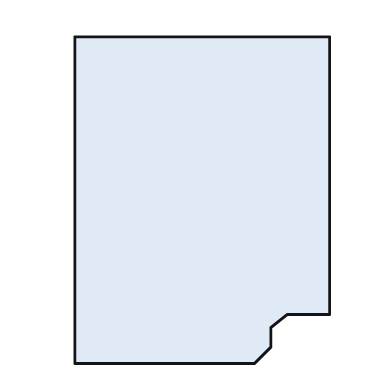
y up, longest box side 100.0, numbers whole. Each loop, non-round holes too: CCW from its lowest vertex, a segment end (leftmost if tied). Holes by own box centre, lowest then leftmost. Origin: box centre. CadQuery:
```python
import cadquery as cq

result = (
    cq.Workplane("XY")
    .moveTo(-39.0, -50.0)
    .lineTo(16.0, -50.0)
    .lineTo(21.0, -45.0)
    .lineTo(21.0, -39.0)
    .lineTo(26.0, -35.0)
    .lineTo(39.0, -35.0)
    .lineTo(39.0, 50.0)
    .lineTo(-39.0, 50.0)
    .close()
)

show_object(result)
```